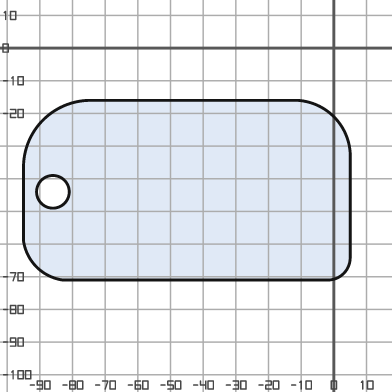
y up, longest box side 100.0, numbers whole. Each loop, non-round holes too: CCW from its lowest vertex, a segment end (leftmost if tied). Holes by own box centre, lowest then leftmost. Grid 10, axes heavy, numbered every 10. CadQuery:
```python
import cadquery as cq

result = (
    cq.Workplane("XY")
    .moveTo(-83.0, -71.0)
    .lineTo(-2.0, -71.0)
    .threePointArc((3.0, -69.0), (5.0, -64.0))
    .lineTo(5.0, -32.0)
    .threePointArc((0.0, -21.0), (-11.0, -16.0))
    .lineTo(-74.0, -16.0)
    .threePointArc((-89.0, -22.0), (-95.0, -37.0))
    .lineTo(-95.0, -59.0)
    .threePointArc((-91.0, -67.0), (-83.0, -71.0))
    .close()
    .moveTo(-86.0, -44.0)
    .circle(5.0)
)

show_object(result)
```